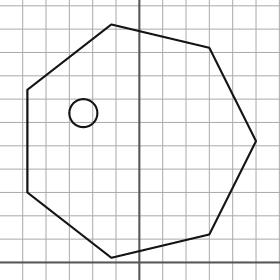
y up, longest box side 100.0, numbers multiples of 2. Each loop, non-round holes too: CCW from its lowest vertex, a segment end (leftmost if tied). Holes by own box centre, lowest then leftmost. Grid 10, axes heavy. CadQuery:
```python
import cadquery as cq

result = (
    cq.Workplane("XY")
    .moveTo(-12.0, 2.0)
    .lineTo(30.0, 12.0)
    .lineTo(50.0, 52.0)
    .lineTo(30.0, 92.0)
    .lineTo(-12.0, 102.0)
    .lineTo(-48.0, 74.0)
    .lineTo(-48.0, 30.0)
    .close()
    .moveTo(-24.0, 64.0)
    .circle(6.0)
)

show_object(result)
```